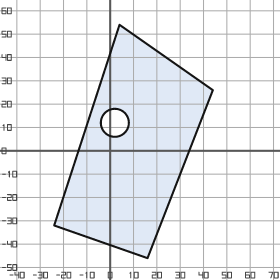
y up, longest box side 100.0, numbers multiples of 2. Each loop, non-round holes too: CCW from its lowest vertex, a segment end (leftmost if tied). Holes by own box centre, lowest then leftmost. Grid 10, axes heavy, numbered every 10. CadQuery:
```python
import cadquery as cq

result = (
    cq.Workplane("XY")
    .moveTo(16.0, -46.0)
    .lineTo(44.0, 26.0)
    .lineTo(4.0, 54.0)
    .lineTo(-24.0, -32.0)
    .close()
    .moveTo(2.0, 12.0)
    .circle(6.0)
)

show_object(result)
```